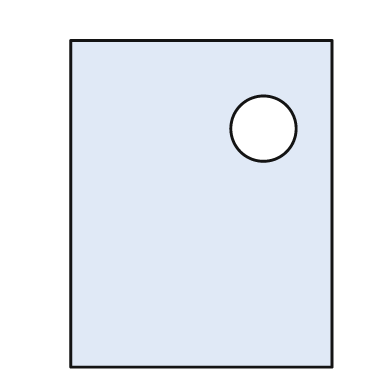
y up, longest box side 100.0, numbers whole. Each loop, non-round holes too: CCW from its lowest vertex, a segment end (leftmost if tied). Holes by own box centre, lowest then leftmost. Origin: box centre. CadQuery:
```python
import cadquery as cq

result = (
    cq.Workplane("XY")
    .moveTo(-40.0, -50.0)
    .lineTo(40.0, -50.0)
    .lineTo(40.0, 50.0)
    .lineTo(-40.0, 50.0)
    .close()
    .moveTo(19.0, 23.0)
    .circle(10.0)
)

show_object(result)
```